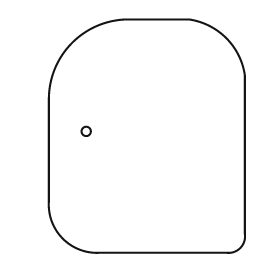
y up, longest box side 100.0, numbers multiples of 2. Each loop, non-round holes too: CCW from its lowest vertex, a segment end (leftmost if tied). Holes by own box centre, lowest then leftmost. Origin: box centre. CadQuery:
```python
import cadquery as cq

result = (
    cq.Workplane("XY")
    .moveTo(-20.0, -50.0)
    .lineTo(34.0, -50.0)
    .threePointArc((40.0, -48.0), (42.0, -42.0))
    .lineTo(42.0, 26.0)
    .threePointArc((34.0, 42.0), (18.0, 50.0))
    .lineTo(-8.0, 50.0)
    .threePointArc((-32.0, 40.0), (-42.0, 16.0))
    .lineTo(-42.0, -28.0)
    .threePointArc((-36.0, -44.0), (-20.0, -50.0))
    .close()
    .moveTo(-26.0, 2.0)
    .circle(2.0)
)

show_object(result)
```